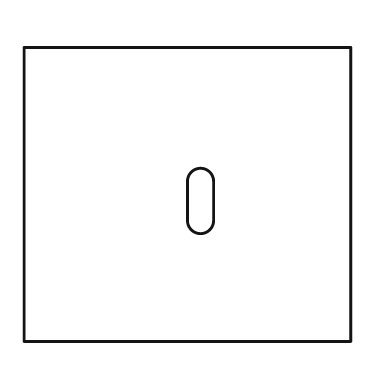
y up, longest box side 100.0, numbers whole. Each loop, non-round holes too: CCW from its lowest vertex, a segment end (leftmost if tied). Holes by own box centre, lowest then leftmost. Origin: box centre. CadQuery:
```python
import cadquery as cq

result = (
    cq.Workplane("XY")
    .moveTo(-50.0, -45.0)
    .lineTo(50.0, -45.0)
    .lineTo(50.0, 45.0)
    .lineTo(-50.0, 45.0)
    .close()
    .moveTo(0.0, -8.0)
    .threePointArc((4.0, -12.0), (8.0, -8.0))
    .lineTo(8.0, 4.0)
    .threePointArc((4.0, 8.0), (0.0, 4.0))
    .close()
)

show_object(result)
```